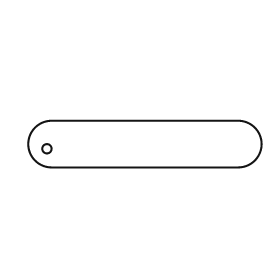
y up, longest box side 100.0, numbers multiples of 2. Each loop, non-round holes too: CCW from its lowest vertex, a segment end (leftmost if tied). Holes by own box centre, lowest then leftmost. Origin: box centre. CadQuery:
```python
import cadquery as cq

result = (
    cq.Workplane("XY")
    .moveTo(-40.0, -10.0)
    .lineTo(40.0, -10.0)
    .threePointArc((50.0, 0.0), (40.0, 10.0))
    .lineTo(-40.0, 10.0)
    .threePointArc((-50.0, 0.0), (-40.0, -10.0))
    .close()
    .moveTo(-42.0, -2.0)
    .circle(2.0)
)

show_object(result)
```